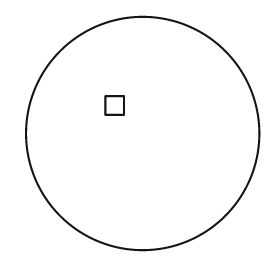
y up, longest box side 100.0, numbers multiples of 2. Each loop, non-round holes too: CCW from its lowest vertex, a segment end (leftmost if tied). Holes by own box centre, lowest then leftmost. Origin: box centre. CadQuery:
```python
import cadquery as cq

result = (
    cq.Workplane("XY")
    .moveTo(0.0, 0.0)
    .circle(50.0)
    .moveTo(-16.0, 8.0)
    .lineTo(-8.0, 8.0)
    .lineTo(-8.0, 16.0)
    .lineTo(-16.0, 16.0)
    .close()
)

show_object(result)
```